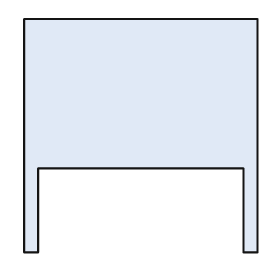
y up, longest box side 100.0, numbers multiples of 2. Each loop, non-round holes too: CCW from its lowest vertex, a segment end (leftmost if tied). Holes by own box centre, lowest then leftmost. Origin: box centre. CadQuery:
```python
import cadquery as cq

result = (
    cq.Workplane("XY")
    .moveTo(-50.0, -50.0)
    .lineTo(-44.0, -50.0)
    .lineTo(-44.0, -14.0)
    .lineTo(44.0, -14.0)
    .lineTo(44.0, -50.0)
    .lineTo(50.0, -50.0)
    .lineTo(50.0, 50.0)
    .lineTo(-50.0, 50.0)
    .close()
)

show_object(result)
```